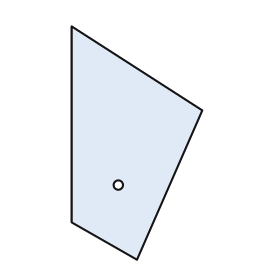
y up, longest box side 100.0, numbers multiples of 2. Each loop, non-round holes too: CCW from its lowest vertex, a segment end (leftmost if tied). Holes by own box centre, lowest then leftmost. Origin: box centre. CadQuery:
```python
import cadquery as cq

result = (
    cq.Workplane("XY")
    .moveTo(0.0, -50.0)
    .lineTo(28.0, 14.0)
    .lineTo(-28.0, 50.0)
    .lineTo(-28.0, -34.0)
    .close()
    .moveTo(-8.0, -18.0)
    .circle(2.0)
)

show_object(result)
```